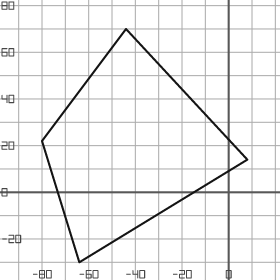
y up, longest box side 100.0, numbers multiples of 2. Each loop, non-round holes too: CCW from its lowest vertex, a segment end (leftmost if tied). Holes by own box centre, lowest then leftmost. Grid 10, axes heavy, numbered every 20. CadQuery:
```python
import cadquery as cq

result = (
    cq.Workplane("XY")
    .moveTo(-64.0, -30.0)
    .lineTo(8.0, 14.0)
    .lineTo(-44.0, 70.0)
    .lineTo(-80.0, 22.0)
    .close()
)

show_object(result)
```